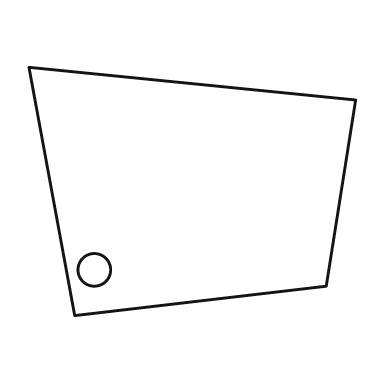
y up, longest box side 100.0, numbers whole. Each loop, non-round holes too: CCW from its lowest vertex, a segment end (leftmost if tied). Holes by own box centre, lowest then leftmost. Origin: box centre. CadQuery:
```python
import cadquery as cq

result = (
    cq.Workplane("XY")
    .moveTo(-36.0, -38.0)
    .lineTo(41.0, -29.0)
    .lineTo(50.0, 28.0)
    .lineTo(-50.0, 38.0)
    .close()
    .moveTo(-30.0, -24.0)
    .circle(5.0)
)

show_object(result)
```